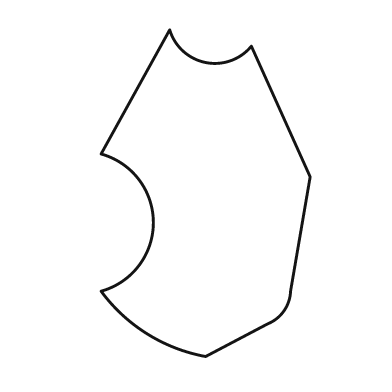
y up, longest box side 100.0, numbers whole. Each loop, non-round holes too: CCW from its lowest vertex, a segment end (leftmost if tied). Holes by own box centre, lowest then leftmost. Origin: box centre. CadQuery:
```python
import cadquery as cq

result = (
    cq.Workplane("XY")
    .moveTo(0.0, -50.0)
    .lineTo(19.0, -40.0)
    .threePointArc((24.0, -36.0), (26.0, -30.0))
    .lineTo(32.0, 5.0)
    .lineTo(14.0, 45.0)
    .threePointArc((0.0, 40.0), (-11.0, 50.0))
    .lineTo(-32.0, 12.0)
    .threePointArc((-16.0, -9.0), (-32.0, -30.0))
    .threePointArc((-18.0, -43.0), (0.0, -50.0))
    .close()
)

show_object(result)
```